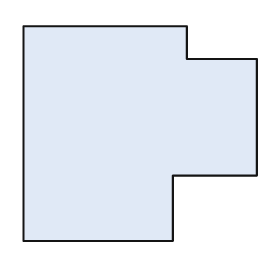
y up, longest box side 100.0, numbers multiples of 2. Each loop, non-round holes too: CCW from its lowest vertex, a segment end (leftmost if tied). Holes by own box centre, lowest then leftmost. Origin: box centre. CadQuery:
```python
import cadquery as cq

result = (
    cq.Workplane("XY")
    .moveTo(-50.0, -46.0)
    .lineTo(14.0, -46.0)
    .lineTo(14.0, -18.0)
    .lineTo(50.0, -18.0)
    .lineTo(50.0, 32.0)
    .lineTo(20.0, 32.0)
    .lineTo(20.0, 46.0)
    .lineTo(-50.0, 46.0)
    .close()
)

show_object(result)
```